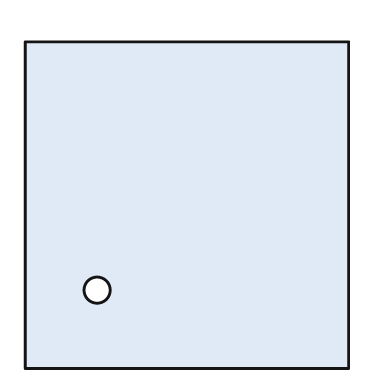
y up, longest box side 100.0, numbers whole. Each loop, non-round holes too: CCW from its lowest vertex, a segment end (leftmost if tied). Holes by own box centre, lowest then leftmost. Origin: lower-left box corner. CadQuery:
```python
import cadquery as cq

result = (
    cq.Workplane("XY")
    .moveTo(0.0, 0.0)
    .lineTo(99.0, 0.0)
    .lineTo(99.0, 100.0)
    .lineTo(0.0, 100.0)
    .close()
    .moveTo(22.0, 24.0)
    .circle(4.0)
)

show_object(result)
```